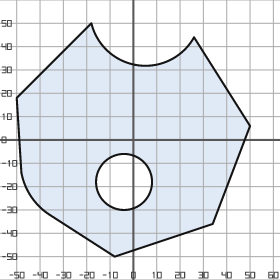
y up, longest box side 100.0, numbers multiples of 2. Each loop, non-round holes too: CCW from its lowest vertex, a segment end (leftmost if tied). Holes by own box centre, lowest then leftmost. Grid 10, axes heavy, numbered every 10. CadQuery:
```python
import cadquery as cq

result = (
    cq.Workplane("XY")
    .moveTo(-8.0, -50.0)
    .lineTo(34.0, -36.0)
    .lineTo(50.0, 6.0)
    .lineTo(26.0, 44.0)
    .threePointArc((2.0, 32.0), (-18.0, 50.0))
    .lineTo(-50.0, 18.0)
    .lineTo(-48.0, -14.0)
    .threePointArc((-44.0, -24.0), (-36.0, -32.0))
    .close()
    .moveTo(-4.0, -18.0)
    .circle(12.0)
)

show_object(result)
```